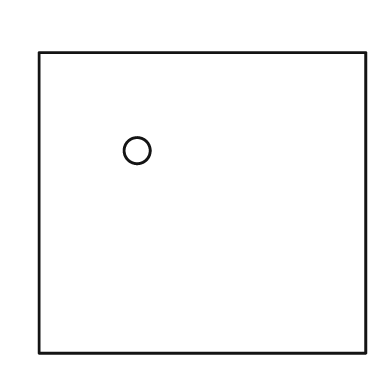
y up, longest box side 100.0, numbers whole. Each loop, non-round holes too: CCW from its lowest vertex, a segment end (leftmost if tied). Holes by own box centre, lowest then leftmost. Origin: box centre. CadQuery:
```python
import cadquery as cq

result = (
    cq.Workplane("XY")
    .moveTo(-50.0, -46.0)
    .lineTo(50.0, -46.0)
    .lineTo(50.0, 46.0)
    .lineTo(-50.0, 46.0)
    .close()
    .moveTo(-20.0, 16.0)
    .circle(4.0)
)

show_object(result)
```